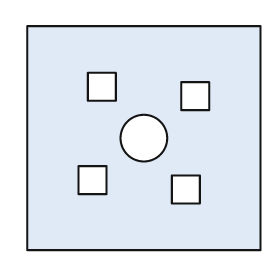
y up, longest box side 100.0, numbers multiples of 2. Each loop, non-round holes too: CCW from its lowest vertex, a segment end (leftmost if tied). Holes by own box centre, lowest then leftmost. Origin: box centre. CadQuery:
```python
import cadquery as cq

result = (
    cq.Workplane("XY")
    .moveTo(-50.0, -48.0)
    .lineTo(50.0, -48.0)
    .lineTo(50.0, 48.0)
    .lineTo(-50.0, 48.0)
    .close()
    .moveTo(12.0, -28.0)
    .lineTo(24.0, -28.0)
    .lineTo(24.0, -16.0)
    .lineTo(12.0, -16.0)
    .close()
    .moveTo(-28.0, -24.0)
    .lineTo(-16.0, -24.0)
    .lineTo(-16.0, -12.0)
    .lineTo(-28.0, -12.0)
    .close()
    .moveTo(0.0, 0.0)
    .circle(10.0)
    .moveTo(16.0, 12.0)
    .lineTo(28.0, 12.0)
    .lineTo(28.0, 24.0)
    .lineTo(16.0, 24.0)
    .close()
    .moveTo(-24.0, 16.0)
    .lineTo(-12.0, 16.0)
    .lineTo(-12.0, 28.0)
    .lineTo(-24.0, 28.0)
    .close()
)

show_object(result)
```